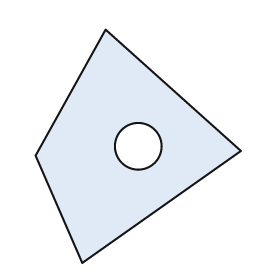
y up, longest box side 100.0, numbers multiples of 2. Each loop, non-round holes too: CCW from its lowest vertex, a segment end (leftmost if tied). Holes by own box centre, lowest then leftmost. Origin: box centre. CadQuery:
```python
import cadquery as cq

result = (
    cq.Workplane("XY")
    .moveTo(-24.0, -50.0)
    .lineTo(44.0, -2.0)
    .lineTo(-14.0, 50.0)
    .lineTo(-44.0, -4.0)
    .close()
    .moveTo(0.0, 0.0)
    .circle(10.0)
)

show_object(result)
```